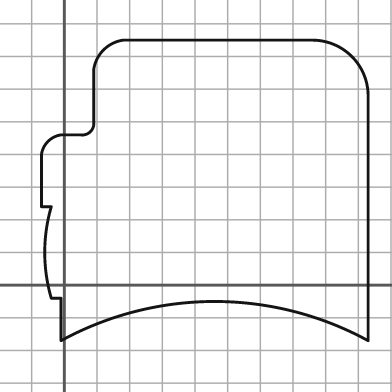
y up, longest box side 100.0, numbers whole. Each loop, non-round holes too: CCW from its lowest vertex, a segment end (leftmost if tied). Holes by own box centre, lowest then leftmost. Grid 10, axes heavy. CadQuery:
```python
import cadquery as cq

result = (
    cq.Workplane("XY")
    .moveTo(-1.0, -17.0)
    .threePointArc((46.0, -5.0), (93.0, -17.0))
    .lineTo(93.0, 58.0)
    .threePointArc((88.0, 70.0), (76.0, 75.0))
    .lineTo(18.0, 75.0)
    .threePointArc((12.0, 72.0), (9.0, 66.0))
    .lineTo(9.0, 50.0)
    .threePointArc((8.0, 47.0), (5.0, 46.0))
    .lineTo(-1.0, 46.0)
    .threePointArc((-5.0, 44.0), (-7.0, 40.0))
    .lineTo(-7.0, 24.0)
    .lineTo(-4.0, 24.0)
    .threePointArc((-6.0, 10.0), (-4.0, -4.0))
    .lineTo(-1.0, -4.0)
    .close()
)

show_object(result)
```